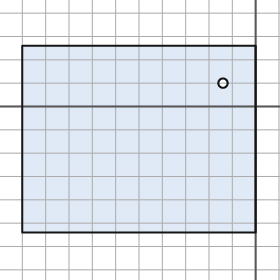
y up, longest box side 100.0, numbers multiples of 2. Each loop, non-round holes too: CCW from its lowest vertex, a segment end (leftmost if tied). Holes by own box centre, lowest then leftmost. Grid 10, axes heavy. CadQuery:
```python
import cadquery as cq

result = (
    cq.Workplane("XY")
    .moveTo(-100.0, -54.0)
    .lineTo(0.0, -54.0)
    .lineTo(0.0, 26.0)
    .lineTo(-100.0, 26.0)
    .close()
    .moveTo(-14.0, 10.0)
    .circle(2.0)
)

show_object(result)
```